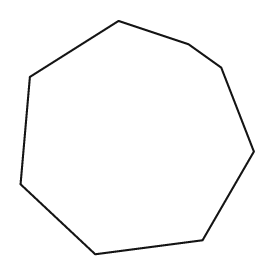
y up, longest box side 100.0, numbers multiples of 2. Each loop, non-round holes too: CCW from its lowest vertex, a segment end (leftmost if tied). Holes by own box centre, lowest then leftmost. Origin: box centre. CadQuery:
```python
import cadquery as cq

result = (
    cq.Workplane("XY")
    .moveTo(-18.0, -50.0)
    .lineTo(28.0, -44.0)
    .lineTo(50.0, -6.0)
    .lineTo(36.0, 30.0)
    .lineTo(22.0, 40.0)
    .lineTo(-8.0, 50.0)
    .lineTo(-46.0, 26.0)
    .lineTo(-50.0, -20.0)
    .close()
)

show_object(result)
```